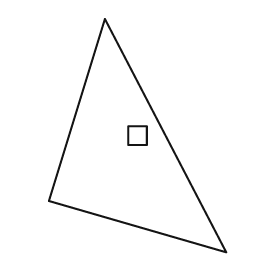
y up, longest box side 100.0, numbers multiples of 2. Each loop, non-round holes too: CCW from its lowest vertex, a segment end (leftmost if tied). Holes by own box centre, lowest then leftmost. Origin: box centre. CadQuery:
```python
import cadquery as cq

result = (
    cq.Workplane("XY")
    .moveTo(38.0, -50.0)
    .lineTo(-14.0, 50.0)
    .lineTo(-38.0, -28.0)
    .close()
    .moveTo(-4.0, -4.0)
    .lineTo(4.0, -4.0)
    .lineTo(4.0, 4.0)
    .lineTo(-4.0, 4.0)
    .close()
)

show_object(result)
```